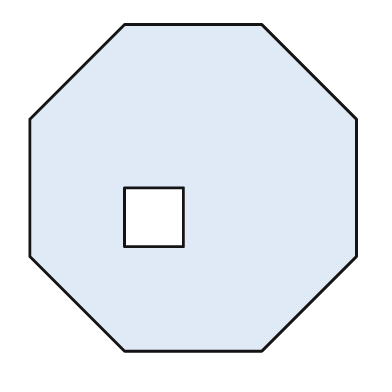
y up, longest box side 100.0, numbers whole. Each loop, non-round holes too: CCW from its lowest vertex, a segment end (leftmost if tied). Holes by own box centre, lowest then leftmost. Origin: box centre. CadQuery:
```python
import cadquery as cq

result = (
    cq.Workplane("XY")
    .moveTo(-21.0, -50.0)
    .lineTo(21.0, -50.0)
    .lineTo(50.0, -21.0)
    .lineTo(50.0, 21.0)
    .lineTo(21.0, 50.0)
    .lineTo(-21.0, 50.0)
    .lineTo(-50.0, 21.0)
    .lineTo(-50.0, -21.0)
    .close()
    .moveTo(-21.0, -18.0)
    .lineTo(-3.0, -18.0)
    .lineTo(-3.0, 0.0)
    .lineTo(-21.0, 0.0)
    .close()
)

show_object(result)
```